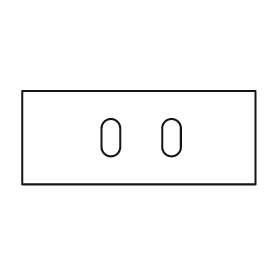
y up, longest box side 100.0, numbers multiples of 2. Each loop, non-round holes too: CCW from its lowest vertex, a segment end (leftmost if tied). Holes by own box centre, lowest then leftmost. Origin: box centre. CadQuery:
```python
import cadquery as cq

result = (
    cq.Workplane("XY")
    .moveTo(-50.0, -20.0)
    .lineTo(50.0, -20.0)
    .lineTo(50.0, 20.0)
    .lineTo(-50.0, 20.0)
    .close()
    .moveTo(-16.0, -4.0)
    .threePointArc((-12.0, -8.0), (-8.0, -4.0))
    .lineTo(-8.0, 4.0)
    .threePointArc((-12.0, 8.0), (-16.0, 4.0))
    .close()
    .moveTo(10.0, -4.0)
    .threePointArc((14.0, -8.0), (18.0, -4.0))
    .lineTo(18.0, 4.0)
    .threePointArc((14.0, 8.0), (10.0, 4.0))
    .close()
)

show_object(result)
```